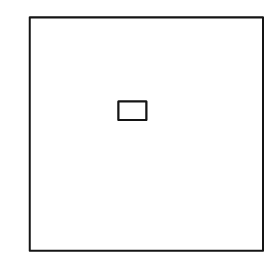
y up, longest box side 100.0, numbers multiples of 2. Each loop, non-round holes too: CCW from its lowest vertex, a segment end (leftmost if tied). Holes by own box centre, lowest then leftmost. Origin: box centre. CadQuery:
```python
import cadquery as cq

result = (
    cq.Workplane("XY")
    .moveTo(-50.0, -50.0)
    .lineTo(50.0, -50.0)
    .lineTo(50.0, 50.0)
    .lineTo(-50.0, 50.0)
    .close()
    .moveTo(-12.0, 6.0)
    .lineTo(0.0, 6.0)
    .lineTo(0.0, 14.0)
    .lineTo(-12.0, 14.0)
    .close()
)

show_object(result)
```